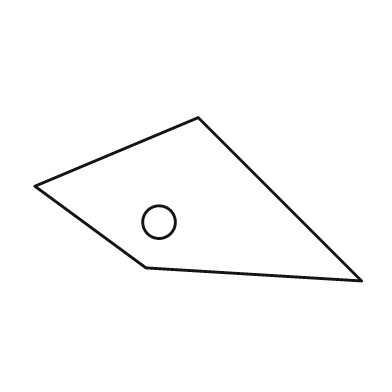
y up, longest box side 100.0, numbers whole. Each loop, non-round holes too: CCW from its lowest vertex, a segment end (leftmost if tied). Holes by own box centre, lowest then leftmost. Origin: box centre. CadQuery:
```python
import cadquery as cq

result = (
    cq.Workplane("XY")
    .moveTo(50.0, -25.0)
    .lineTo(0.0, 25.0)
    .lineTo(-50.0, 4.0)
    .lineTo(-16.0, -21.0)
    .close()
    .moveTo(-12.0, -7.0)
    .circle(5.0)
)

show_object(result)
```